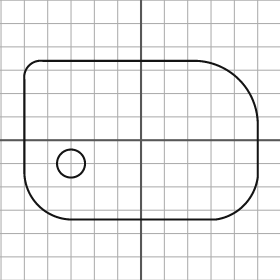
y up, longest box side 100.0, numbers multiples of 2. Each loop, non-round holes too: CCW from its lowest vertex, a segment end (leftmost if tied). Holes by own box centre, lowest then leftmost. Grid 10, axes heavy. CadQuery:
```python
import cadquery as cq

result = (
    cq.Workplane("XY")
    .moveTo(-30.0, -34.0)
    .lineTo(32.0, -34.0)
    .threePointArc((44.0, -28.0), (50.0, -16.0))
    .lineTo(50.0, 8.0)
    .threePointArc((42.0, 26.0), (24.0, 34.0))
    .lineTo(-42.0, 34.0)
    .threePointArc((-48.0, 32.0), (-50.0, 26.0))
    .lineTo(-50.0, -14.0)
    .threePointArc((-44.0, -28.0), (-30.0, -34.0))
    .close()
    .moveTo(-30.0, -10.0)
    .circle(6.0)
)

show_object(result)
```